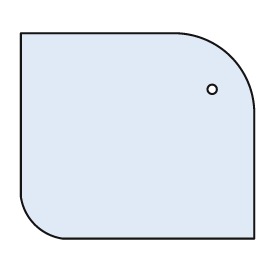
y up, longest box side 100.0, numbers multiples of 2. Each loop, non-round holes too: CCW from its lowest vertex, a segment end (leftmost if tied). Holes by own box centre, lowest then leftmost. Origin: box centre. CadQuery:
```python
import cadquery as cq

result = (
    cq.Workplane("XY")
    .moveTo(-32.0, -44.0)
    .lineTo(50.0, -44.0)
    .lineTo(50.0, 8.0)
    .threePointArc((40.0, 34.0), (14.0, 44.0))
    .lineTo(-50.0, 44.0)
    .lineTo(-50.0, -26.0)
    .threePointArc((-44.0, -38.0), (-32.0, -44.0))
    .close()
    .moveTo(32.0, 20.0)
    .circle(2.0)
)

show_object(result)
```